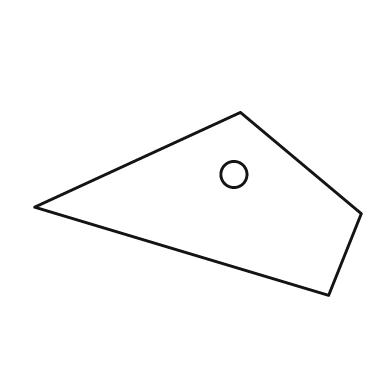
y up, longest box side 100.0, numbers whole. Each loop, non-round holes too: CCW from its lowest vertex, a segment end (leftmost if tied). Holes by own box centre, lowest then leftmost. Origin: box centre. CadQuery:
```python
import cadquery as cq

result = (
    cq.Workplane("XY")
    .moveTo(40.0, -28.0)
    .lineTo(50.0, -3.0)
    .lineTo(13.0, 28.0)
    .lineTo(-50.0, -1.0)
    .close()
    .moveTo(11.0, 9.0)
    .circle(4.0)
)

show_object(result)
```